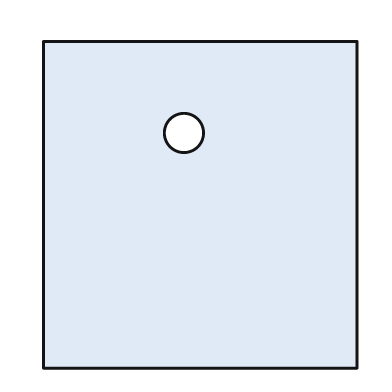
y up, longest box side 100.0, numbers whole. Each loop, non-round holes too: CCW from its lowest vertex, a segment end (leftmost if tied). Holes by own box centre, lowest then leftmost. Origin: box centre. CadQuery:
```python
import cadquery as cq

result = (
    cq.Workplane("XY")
    .moveTo(-48.0, -50.0)
    .lineTo(48.0, -50.0)
    .lineTo(48.0, 50.0)
    .lineTo(-48.0, 50.0)
    .close()
    .moveTo(-5.0, 22.0)
    .circle(6.0)
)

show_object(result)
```